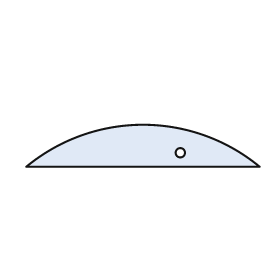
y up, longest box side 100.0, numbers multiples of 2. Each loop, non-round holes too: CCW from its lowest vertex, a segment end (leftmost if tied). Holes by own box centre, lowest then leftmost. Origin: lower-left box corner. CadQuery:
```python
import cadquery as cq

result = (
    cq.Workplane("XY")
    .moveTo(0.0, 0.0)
    .lineTo(100.0, 0.0)
    .threePointArc((50.0, 18.0), (0.0, 0.0))
    .close()
    .moveTo(66.0, 6.0)
    .circle(2.0)
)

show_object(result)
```